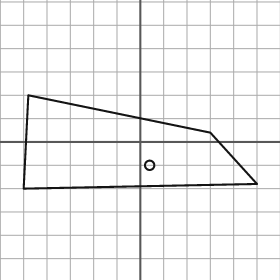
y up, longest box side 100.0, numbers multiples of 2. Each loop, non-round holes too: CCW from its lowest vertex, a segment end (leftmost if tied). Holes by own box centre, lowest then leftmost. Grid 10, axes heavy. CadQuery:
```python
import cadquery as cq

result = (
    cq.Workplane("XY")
    .moveTo(-50.0, -20.0)
    .lineTo(50.0, -18.0)
    .lineTo(30.0, 4.0)
    .lineTo(-48.0, 20.0)
    .close()
    .moveTo(4.0, -10.0)
    .circle(2.0)
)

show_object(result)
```